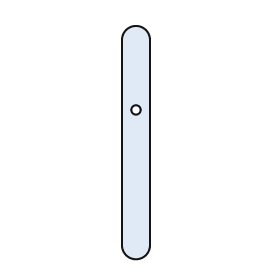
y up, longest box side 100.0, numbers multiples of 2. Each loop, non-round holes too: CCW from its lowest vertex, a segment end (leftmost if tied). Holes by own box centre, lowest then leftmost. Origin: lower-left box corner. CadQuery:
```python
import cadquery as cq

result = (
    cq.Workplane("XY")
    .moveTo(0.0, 6.0)
    .threePointArc((6.0, 0.0), (12.0, 6.0))
    .lineTo(12.0, 94.0)
    .threePointArc((6.0, 100.0), (0.0, 94.0))
    .close()
    .moveTo(6.0, 64.0)
    .circle(2.0)
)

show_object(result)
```